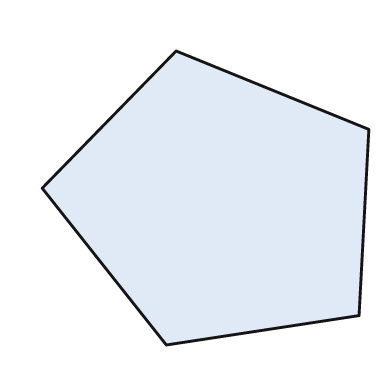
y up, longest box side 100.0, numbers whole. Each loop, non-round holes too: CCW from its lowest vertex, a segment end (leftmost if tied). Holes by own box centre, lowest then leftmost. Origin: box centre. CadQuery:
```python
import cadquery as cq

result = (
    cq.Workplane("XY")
    .moveTo(-12.0, -45.0)
    .lineTo(47.0, -36.0)
    .lineTo(50.0, 21.0)
    .lineTo(-9.0, 45.0)
    .lineTo(-50.0, 3.0)
    .close()
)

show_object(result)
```